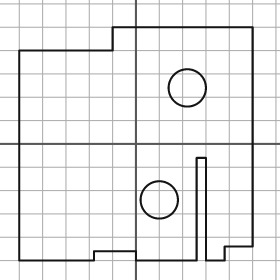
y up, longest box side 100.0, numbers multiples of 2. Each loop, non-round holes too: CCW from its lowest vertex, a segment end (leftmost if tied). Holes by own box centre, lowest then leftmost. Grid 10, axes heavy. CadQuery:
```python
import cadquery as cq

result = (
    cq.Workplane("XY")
    .moveTo(-50.0, -50.0)
    .lineTo(-18.0, -50.0)
    .lineTo(-18.0, -46.0)
    .lineTo(0.0, -46.0)
    .lineTo(0.0, -50.0)
    .lineTo(26.0, -50.0)
    .lineTo(26.0, -6.0)
    .lineTo(30.0, -6.0)
    .lineTo(30.0, -50.0)
    .lineTo(38.0, -50.0)
    .lineTo(38.0, -44.0)
    .lineTo(50.0, -44.0)
    .lineTo(50.0, 50.0)
    .lineTo(-10.0, 50.0)
    .lineTo(-10.0, 40.0)
    .lineTo(-50.0, 40.0)
    .close()
    .moveTo(10.0, -24.0)
    .circle(8.0)
    .moveTo(22.0, 24.0)
    .circle(8.0)
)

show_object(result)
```